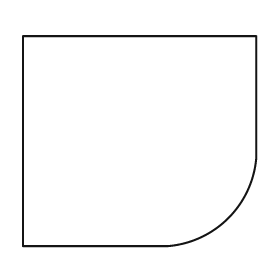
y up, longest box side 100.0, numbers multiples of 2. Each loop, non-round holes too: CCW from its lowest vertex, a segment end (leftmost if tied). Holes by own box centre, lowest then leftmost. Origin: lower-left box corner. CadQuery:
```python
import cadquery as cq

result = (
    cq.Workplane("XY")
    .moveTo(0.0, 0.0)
    .lineTo(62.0, 0.0)
    .threePointArc((88.0, 12.0), (100.0, 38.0))
    .lineTo(100.0, 90.0)
    .lineTo(0.0, 90.0)
    .close()
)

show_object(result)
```